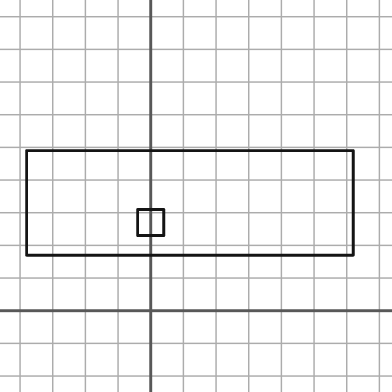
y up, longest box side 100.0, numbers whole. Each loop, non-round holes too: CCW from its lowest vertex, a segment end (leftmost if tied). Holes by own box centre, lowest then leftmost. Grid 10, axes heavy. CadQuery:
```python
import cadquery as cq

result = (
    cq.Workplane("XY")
    .moveTo(-38.0, 17.0)
    .lineTo(62.0, 17.0)
    .lineTo(62.0, 49.0)
    .lineTo(-38.0, 49.0)
    .close()
    .moveTo(-4.0, 23.0)
    .lineTo(4.0, 23.0)
    .lineTo(4.0, 31.0)
    .lineTo(-4.0, 31.0)
    .close()
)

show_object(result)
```